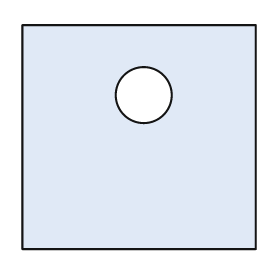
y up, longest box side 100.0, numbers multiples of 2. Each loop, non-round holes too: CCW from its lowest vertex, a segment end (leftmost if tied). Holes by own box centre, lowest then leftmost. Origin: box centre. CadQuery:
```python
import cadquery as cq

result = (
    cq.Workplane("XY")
    .moveTo(-50.0, -48.0)
    .lineTo(50.0, -48.0)
    .lineTo(50.0, 48.0)
    .lineTo(-50.0, 48.0)
    .close()
    .moveTo(2.0, 18.0)
    .circle(12.0)
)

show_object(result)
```